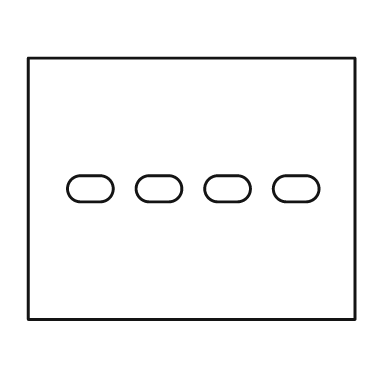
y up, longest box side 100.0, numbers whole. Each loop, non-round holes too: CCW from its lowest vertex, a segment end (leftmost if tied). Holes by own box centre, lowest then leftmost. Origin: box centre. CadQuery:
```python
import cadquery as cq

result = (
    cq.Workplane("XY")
    .moveTo(-50.0, -40.0)
    .lineTo(50.0, -40.0)
    .lineTo(50.0, 40.0)
    .lineTo(-50.0, 40.0)
    .close()
    .moveTo(-34.0, -4.0)
    .lineTo(-28.0, -4.0)
    .threePointArc((-24.0, 0.0), (-28.0, 4.0))
    .lineTo(-34.0, 4.0)
    .threePointArc((-38.0, 0.0), (-34.0, -4.0))
    .close()
    .moveTo(-13.0, -4.0)
    .lineTo(-7.0, -4.0)
    .threePointArc((-3.0, 0.0), (-7.0, 4.0))
    .lineTo(-13.0, 4.0)
    .threePointArc((-17.0, 0.0), (-13.0, -4.0))
    .close()
    .moveTo(8.0, -4.0)
    .lineTo(14.0, -4.0)
    .threePointArc((18.0, 0.0), (14.0, 4.0))
    .lineTo(8.0, 4.0)
    .threePointArc((4.0, 0.0), (8.0, -4.0))
    .close()
    .moveTo(29.0, -4.0)
    .lineTo(35.0, -4.0)
    .threePointArc((39.0, 0.0), (35.0, 4.0))
    .lineTo(29.0, 4.0)
    .threePointArc((25.0, 0.0), (29.0, -4.0))
    .close()
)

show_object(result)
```